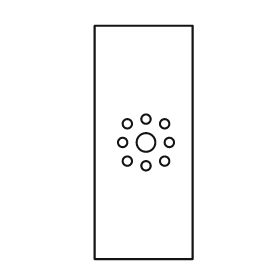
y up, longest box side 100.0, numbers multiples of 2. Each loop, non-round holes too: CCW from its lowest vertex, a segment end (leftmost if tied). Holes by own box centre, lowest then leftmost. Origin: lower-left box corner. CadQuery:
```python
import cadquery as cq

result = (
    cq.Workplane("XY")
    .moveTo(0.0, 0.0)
    .lineTo(42.0, 0.0)
    .lineTo(42.0, 100.0)
    .lineTo(0.0, 100.0)
    .close()
    .moveTo(22.0, 40.0)
    .circle(2.0)
    .moveTo(14.0, 42.0)
    .circle(2.0)
    .moveTo(30.0, 42.0)
    .circle(2.0)
    .moveTo(12.0, 50.0)
    .circle(2.0)
    .moveTo(22.0, 50.0)
    .circle(4.0)
    .moveTo(32.0, 50.0)
    .circle(2.0)
    .moveTo(14.0, 58.0)
    .circle(2.0)
    .moveTo(30.0, 58.0)
    .circle(2.0)
    .moveTo(22.0, 60.0)
    .circle(2.0)
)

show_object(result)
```